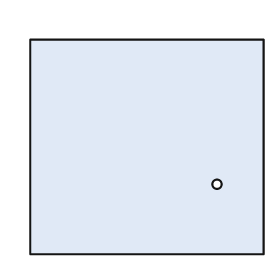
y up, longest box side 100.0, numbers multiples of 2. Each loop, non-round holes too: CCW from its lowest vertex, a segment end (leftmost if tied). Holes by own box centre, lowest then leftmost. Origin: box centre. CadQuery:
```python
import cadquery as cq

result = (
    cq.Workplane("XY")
    .moveTo(-50.0, -46.0)
    .lineTo(50.0, -46.0)
    .lineTo(50.0, 46.0)
    .lineTo(-50.0, 46.0)
    .close()
    .moveTo(30.0, -16.0)
    .circle(2.0)
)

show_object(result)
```